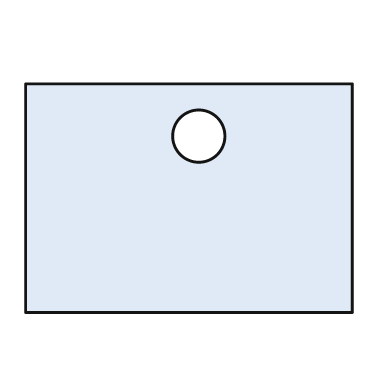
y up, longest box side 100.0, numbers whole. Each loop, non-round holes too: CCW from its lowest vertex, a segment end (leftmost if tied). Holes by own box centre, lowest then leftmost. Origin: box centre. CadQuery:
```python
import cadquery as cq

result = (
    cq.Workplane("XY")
    .moveTo(-50.0, -35.0)
    .lineTo(50.0, -35.0)
    .lineTo(50.0, 35.0)
    .lineTo(-50.0, 35.0)
    .close()
    .moveTo(3.0, 19.0)
    .circle(8.0)
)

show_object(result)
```